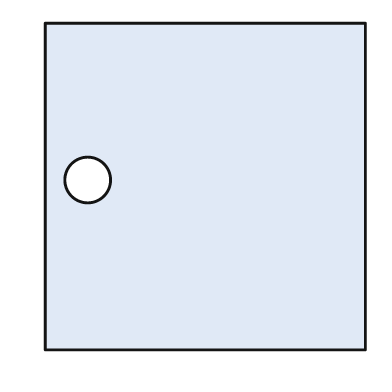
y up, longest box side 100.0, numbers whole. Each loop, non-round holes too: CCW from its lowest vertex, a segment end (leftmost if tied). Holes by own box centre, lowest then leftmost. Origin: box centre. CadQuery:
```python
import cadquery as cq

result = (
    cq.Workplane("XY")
    .moveTo(-49.0, -50.0)
    .lineTo(49.0, -50.0)
    .lineTo(49.0, 50.0)
    .lineTo(-49.0, 50.0)
    .close()
    .moveTo(-36.0, 2.0)
    .circle(7.0)
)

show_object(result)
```